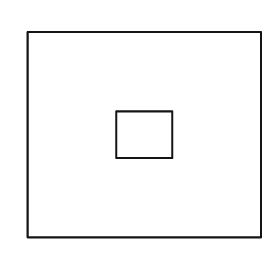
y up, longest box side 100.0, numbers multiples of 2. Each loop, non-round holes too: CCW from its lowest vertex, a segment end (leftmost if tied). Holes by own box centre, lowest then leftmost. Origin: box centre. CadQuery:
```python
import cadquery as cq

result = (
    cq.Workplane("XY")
    .moveTo(-50.0, -44.0)
    .lineTo(50.0, -44.0)
    .lineTo(50.0, 44.0)
    .lineTo(-50.0, 44.0)
    .close()
    .moveTo(-12.0, -10.0)
    .lineTo(12.0, -10.0)
    .lineTo(12.0, 10.0)
    .lineTo(-12.0, 10.0)
    .close()
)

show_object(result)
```